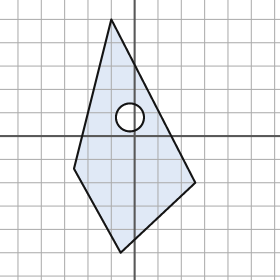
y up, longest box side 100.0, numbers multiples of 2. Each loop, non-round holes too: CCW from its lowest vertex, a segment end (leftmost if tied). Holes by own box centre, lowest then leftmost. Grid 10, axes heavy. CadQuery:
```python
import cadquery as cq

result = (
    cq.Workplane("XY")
    .moveTo(-6.0, -50.0)
    .lineTo(26.0, -20.0)
    .lineTo(-10.0, 50.0)
    .lineTo(-26.0, -14.0)
    .close()
    .moveTo(-2.0, 8.0)
    .circle(6.0)
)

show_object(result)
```